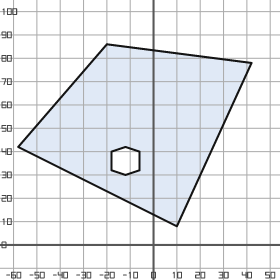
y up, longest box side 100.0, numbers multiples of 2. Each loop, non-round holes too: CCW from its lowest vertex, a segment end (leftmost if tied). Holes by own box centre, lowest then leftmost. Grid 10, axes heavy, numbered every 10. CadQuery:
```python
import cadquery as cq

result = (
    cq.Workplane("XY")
    .moveTo(10.0, 8.0)
    .lineTo(42.0, 78.0)
    .lineTo(-20.0, 86.0)
    .lineTo(-58.0, 42.0)
    .close()
    .moveTo(-12.0, 30.0)
    .lineTo(-6.0, 32.0)
    .lineTo(-6.0, 40.0)
    .lineTo(-12.0, 42.0)
    .lineTo(-18.0, 40.0)
    .lineTo(-18.0, 32.0)
    .close()
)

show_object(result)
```